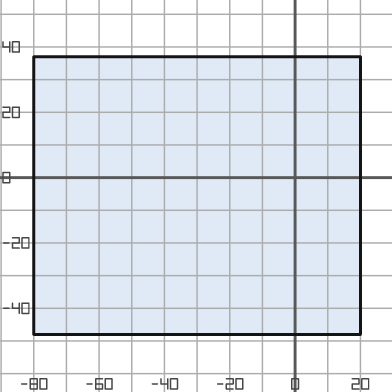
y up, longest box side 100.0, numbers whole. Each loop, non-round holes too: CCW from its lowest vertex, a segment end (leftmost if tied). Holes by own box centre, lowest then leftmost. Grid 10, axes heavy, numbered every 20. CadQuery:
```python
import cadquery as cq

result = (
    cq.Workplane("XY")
    .moveTo(-80.0, -48.0)
    .lineTo(20.0, -48.0)
    .lineTo(20.0, 37.0)
    .lineTo(-80.0, 37.0)
    .close()
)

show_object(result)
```